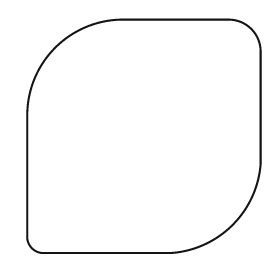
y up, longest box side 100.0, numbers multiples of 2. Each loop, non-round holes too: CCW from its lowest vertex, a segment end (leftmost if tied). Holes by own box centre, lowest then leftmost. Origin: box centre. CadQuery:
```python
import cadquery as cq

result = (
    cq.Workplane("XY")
    .moveTo(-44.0, -50.0)
    .lineTo(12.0, -50.0)
    .threePointArc((38.0, -38.0), (50.0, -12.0))
    .lineTo(50.0, 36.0)
    .threePointArc((46.0, 46.0), (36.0, 50.0))
    .lineTo(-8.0, 50.0)
    .threePointArc((-38.0, 38.0), (-50.0, 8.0))
    .lineTo(-50.0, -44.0)
    .threePointArc((-48.0, -48.0), (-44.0, -50.0))
    .close()
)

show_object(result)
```